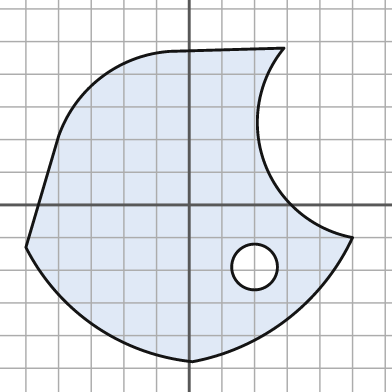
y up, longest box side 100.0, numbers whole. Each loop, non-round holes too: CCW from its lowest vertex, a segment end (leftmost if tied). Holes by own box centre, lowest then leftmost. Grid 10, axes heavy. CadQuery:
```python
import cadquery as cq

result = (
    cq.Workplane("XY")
    .moveTo(1.0, -48.0)
    .threePointArc((30.0, -35.0), (50.0, -10.0))
    .threePointArc((23.0, 13.0), (29.0, 48.0))
    .lineTo(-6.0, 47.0)
    .threePointArc((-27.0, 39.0), (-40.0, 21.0))
    .lineTo(-50.0, -13.0)
    .threePointArc((-29.0, -37.0), (1.0, -48.0))
    .close()
    .moveTo(20.0, -19.0)
    .circle(7.0)
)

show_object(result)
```